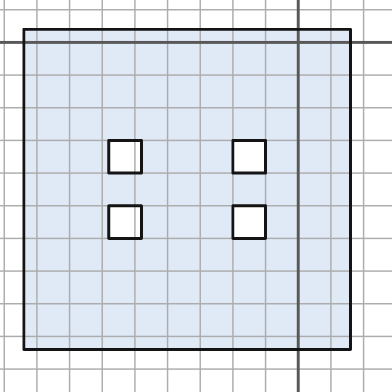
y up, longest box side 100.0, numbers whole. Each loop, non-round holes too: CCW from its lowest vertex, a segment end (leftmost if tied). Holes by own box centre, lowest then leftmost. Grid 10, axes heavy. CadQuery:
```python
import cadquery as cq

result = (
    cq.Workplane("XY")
    .moveTo(-84.0, -94.0)
    .lineTo(16.0, -94.0)
    .lineTo(16.0, 4.0)
    .lineTo(-84.0, 4.0)
    .close()
    .moveTo(-58.0, -60.0)
    .lineTo(-48.0, -60.0)
    .lineTo(-48.0, -50.0)
    .lineTo(-58.0, -50.0)
    .close()
    .moveTo(-20.0, -60.0)
    .lineTo(-10.0, -60.0)
    .lineTo(-10.0, -50.0)
    .lineTo(-20.0, -50.0)
    .close()
    .moveTo(-58.0, -40.0)
    .lineTo(-48.0, -40.0)
    .lineTo(-48.0, -30.0)
    .lineTo(-58.0, -30.0)
    .close()
    .moveTo(-20.0, -40.0)
    .lineTo(-10.0, -40.0)
    .lineTo(-10.0, -30.0)
    .lineTo(-20.0, -30.0)
    .close()
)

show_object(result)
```